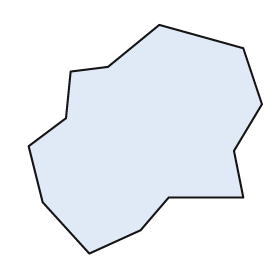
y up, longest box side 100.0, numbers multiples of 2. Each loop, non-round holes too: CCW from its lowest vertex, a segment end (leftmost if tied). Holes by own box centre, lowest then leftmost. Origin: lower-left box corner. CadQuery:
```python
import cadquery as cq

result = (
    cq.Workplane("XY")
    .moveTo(26.0, 0.0)
    .lineTo(48.0, 10.0)
    .lineTo(60.0, 24.0)
    .lineTo(92.0, 24.0)
    .lineTo(88.0, 44.0)
    .lineTo(100.0, 64.0)
    .lineTo(92.0, 88.0)
    .lineTo(56.0, 98.0)
    .lineTo(34.0, 80.0)
    .lineTo(18.0, 78.0)
    .lineTo(16.0, 58.0)
    .lineTo(0.0, 46.0)
    .lineTo(6.0, 22.0)
    .close()
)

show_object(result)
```